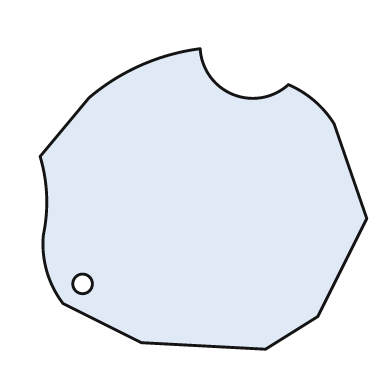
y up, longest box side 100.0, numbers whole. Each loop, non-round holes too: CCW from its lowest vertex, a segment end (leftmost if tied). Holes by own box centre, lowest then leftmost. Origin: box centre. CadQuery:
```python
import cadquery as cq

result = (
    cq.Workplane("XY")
    .moveTo(19.0, -46.0)
    .lineTo(35.0, -36.0)
    .lineTo(50.0, -6.0)
    .lineTo(40.0, 23.0)
    .threePointArc((34.0, 30.0), (26.0, 35.0))
    .threePointArc((9.0, 32.0), (-1.0, 46.0))
    .threePointArc((-19.0, 41.0), (-35.0, 31.0))
    .lineTo(-50.0, 13.0)
    .threePointArc((-48.0, 1.0), (-49.0, -11.0))
    .threePointArc((-48.0, -22.0), (-43.0, -32.0))
    .lineTo(-19.0, -44.0)
    .close()
    .moveTo(-37.0, -26.0)
    .circle(3.0)
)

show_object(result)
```